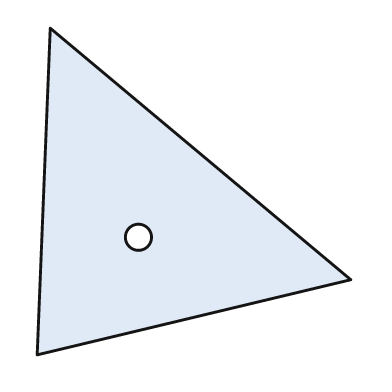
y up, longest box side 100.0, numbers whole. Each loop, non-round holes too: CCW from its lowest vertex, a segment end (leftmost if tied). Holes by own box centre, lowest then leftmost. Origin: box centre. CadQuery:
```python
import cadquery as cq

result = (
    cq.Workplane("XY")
    .moveTo(-48.0, -50.0)
    .lineTo(48.0, -27.0)
    .lineTo(-44.0, 50.0)
    .close()
    .moveTo(-17.0, -14.0)
    .circle(4.0)
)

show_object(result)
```